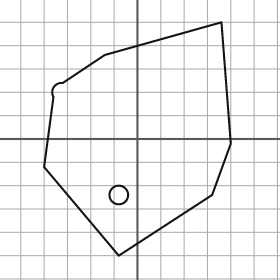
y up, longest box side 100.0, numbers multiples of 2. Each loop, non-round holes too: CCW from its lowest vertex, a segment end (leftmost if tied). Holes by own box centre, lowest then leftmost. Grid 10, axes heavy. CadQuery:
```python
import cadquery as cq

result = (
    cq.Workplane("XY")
    .moveTo(-8.0, -50.0)
    .lineTo(32.0, -24.0)
    .lineTo(40.0, -2.0)
    .lineTo(36.0, 50.0)
    .lineTo(-14.0, 36.0)
    .lineTo(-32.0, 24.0)
    .threePointArc((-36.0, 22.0), (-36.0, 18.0))
    .lineTo(-40.0, -12.0)
    .close()
    .moveTo(-8.0, -24.0)
    .circle(4.0)
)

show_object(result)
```